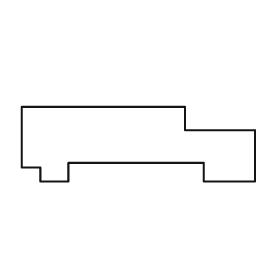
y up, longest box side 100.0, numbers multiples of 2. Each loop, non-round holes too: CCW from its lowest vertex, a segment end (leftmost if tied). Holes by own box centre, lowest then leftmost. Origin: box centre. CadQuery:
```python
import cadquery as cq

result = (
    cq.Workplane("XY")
    .moveTo(-42.0, -16.0)
    .lineTo(-30.0, -16.0)
    .lineTo(-30.0, -8.0)
    .lineTo(28.0, -8.0)
    .lineTo(28.0, -16.0)
    .lineTo(50.0, -16.0)
    .lineTo(50.0, 6.0)
    .lineTo(20.0, 6.0)
    .lineTo(20.0, 16.0)
    .lineTo(-50.0, 16.0)
    .lineTo(-50.0, -10.0)
    .lineTo(-42.0, -10.0)
    .close()
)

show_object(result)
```